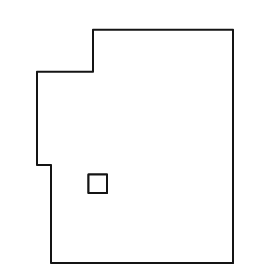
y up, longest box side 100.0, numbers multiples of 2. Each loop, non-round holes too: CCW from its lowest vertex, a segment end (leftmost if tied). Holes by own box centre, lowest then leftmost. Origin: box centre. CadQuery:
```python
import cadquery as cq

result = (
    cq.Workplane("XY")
    .moveTo(-36.0, -50.0)
    .lineTo(42.0, -50.0)
    .lineTo(42.0, 50.0)
    .lineTo(-18.0, 50.0)
    .lineTo(-18.0, 32.0)
    .lineTo(-42.0, 32.0)
    .lineTo(-42.0, -8.0)
    .lineTo(-36.0, -8.0)
    .close()
    .moveTo(-20.0, -20.0)
    .lineTo(-12.0, -20.0)
    .lineTo(-12.0, -12.0)
    .lineTo(-20.0, -12.0)
    .close()
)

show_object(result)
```